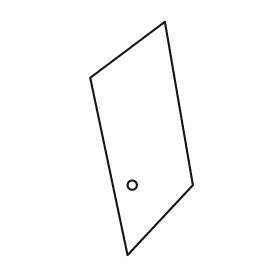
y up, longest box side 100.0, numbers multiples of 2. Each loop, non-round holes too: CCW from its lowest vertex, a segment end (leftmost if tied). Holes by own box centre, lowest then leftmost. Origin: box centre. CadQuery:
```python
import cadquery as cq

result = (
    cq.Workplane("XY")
    .moveTo(-6.0, -50.0)
    .lineTo(22.0, -20.0)
    .lineTo(10.0, 50.0)
    .lineTo(-22.0, 26.0)
    .close()
    .moveTo(-4.0, -20.0)
    .circle(2.0)
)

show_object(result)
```